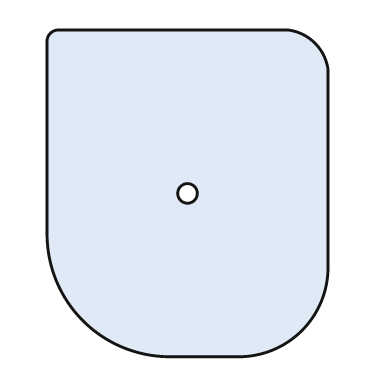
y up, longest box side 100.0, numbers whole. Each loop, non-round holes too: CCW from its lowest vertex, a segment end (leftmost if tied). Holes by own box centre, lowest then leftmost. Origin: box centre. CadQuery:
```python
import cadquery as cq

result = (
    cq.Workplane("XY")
    .moveTo(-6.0, -50.0)
    .lineTo(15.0, -50.0)
    .threePointArc((35.0, -42.0), (43.0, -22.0))
    .lineTo(43.0, 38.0)
    .threePointArc((39.0, 46.0), (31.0, 50.0))
    .lineTo(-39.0, 50.0)
    .threePointArc((-42.0, 49.0), (-43.0, 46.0))
    .lineTo(-43.0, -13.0)
    .threePointArc((-32.0, -39.0), (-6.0, -50.0))
    .close()
    .moveTo(0.0, 0.0)
    .circle(3.0)
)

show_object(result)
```